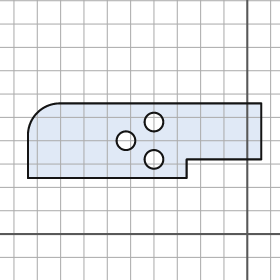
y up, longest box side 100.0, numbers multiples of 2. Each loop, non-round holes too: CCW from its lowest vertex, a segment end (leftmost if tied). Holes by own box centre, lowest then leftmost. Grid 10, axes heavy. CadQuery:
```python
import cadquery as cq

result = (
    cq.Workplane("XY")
    .moveTo(-94.0, 24.0)
    .lineTo(-26.0, 24.0)
    .lineTo(-26.0, 32.0)
    .lineTo(6.0, 32.0)
    .lineTo(6.0, 56.0)
    .lineTo(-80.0, 56.0)
    .threePointArc((-90.0, 52.0), (-94.0, 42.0))
    .close()
    .moveTo(-40.0, 32.0)
    .circle(4.0)
    .moveTo(-52.0, 40.0)
    .circle(4.0)
    .moveTo(-40.0, 48.0)
    .circle(4.0)
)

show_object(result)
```